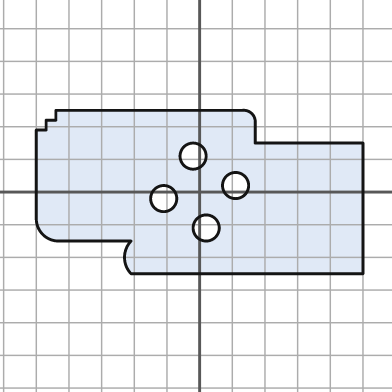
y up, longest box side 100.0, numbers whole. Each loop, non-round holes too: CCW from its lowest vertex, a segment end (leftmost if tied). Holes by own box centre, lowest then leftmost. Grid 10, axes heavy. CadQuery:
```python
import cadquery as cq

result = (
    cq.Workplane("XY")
    .moveTo(-21.0, -25.0)
    .lineTo(50.0, -25.0)
    .lineTo(50.0, 15.0)
    .lineTo(17.0, 15.0)
    .lineTo(17.0, 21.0)
    .threePointArc((16.0, 24.0), (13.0, 25.0))
    .lineTo(-44.0, 25.0)
    .lineTo(-44.0, 22.0)
    .lineTo(-47.0, 22.0)
    .lineTo(-47.0, 19.0)
    .lineTo(-50.0, 19.0)
    .lineTo(-50.0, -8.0)
    .threePointArc((-48.0, -13.0), (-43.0, -15.0))
    .lineTo(-21.0, -15.0)
    .threePointArc((-23.0, -20.0), (-21.0, -25.0))
    .close()
    .moveTo(2.0, -11.0)
    .circle(4.0)
    .moveTo(-11.0, -2.0)
    .circle(4.0)
    .moveTo(11.0, 2.0)
    .circle(4.0)
    .moveTo(-2.0, 11.0)
    .circle(4.0)
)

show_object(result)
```